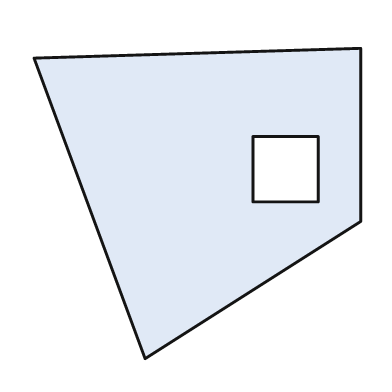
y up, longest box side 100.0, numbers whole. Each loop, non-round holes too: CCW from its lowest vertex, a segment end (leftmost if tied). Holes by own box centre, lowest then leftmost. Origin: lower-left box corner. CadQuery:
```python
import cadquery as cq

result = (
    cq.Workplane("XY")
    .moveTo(34.0, 0.0)
    .lineTo(100.0, 42.0)
    .lineTo(100.0, 95.0)
    .lineTo(0.0, 92.0)
    .close()
    .moveTo(67.0, 48.0)
    .lineTo(87.0, 48.0)
    .lineTo(87.0, 68.0)
    .lineTo(67.0, 68.0)
    .close()
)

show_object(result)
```